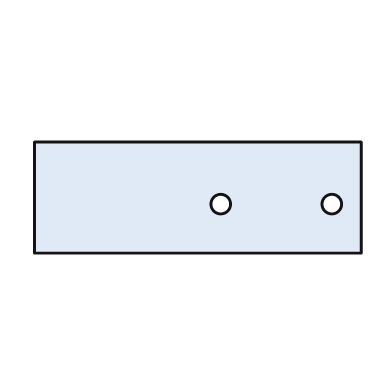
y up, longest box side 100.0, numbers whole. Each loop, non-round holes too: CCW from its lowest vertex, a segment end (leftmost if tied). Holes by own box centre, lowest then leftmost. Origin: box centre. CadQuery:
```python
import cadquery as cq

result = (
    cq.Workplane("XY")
    .moveTo(-50.0, -17.0)
    .lineTo(50.0, -17.0)
    .lineTo(50.0, 17.0)
    .lineTo(-50.0, 17.0)
    .close()
    .moveTo(7.0, -2.0)
    .circle(3.0)
    .moveTo(41.0, -2.0)
    .circle(3.0)
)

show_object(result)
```